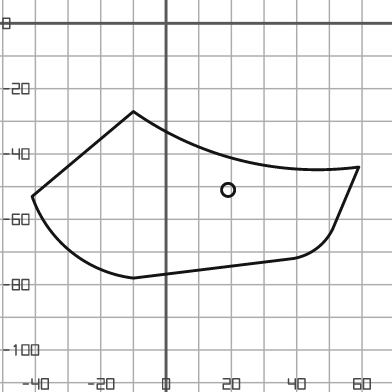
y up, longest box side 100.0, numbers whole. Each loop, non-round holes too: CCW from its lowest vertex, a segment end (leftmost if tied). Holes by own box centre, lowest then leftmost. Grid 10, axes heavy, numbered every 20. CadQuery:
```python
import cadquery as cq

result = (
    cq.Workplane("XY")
    .moveTo(-10.0, -78.0)
    .lineTo(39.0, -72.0)
    .threePointArc((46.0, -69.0), (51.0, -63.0))
    .lineTo(59.0, -44.0)
    .threePointArc((23.0, -42.0), (-10.0, -27.0))
    .lineTo(-41.0, -53.0)
    .threePointArc((-29.0, -70.0), (-10.0, -78.0))
    .close()
    .moveTo(19.0, -51.0)
    .circle(2.0)
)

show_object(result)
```